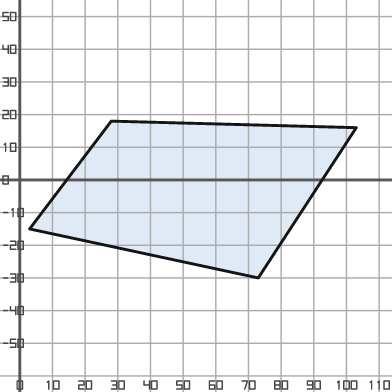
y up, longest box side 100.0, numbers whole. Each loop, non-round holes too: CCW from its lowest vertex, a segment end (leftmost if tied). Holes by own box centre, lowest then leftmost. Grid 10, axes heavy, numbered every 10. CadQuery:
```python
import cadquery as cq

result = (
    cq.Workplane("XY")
    .moveTo(73.0, -30.0)
    .lineTo(103.0, 16.0)
    .lineTo(28.0, 18.0)
    .lineTo(3.0, -15.0)
    .close()
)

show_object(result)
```